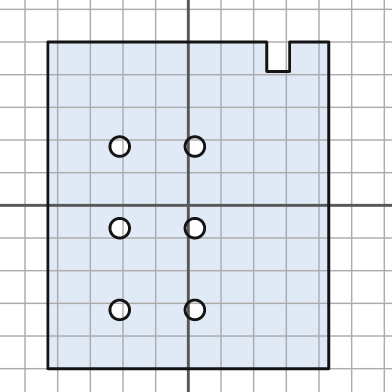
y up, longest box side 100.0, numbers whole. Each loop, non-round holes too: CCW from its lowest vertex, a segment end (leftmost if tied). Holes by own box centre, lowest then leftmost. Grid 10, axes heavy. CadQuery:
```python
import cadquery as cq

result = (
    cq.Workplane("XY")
    .moveTo(-43.0, -50.0)
    .lineTo(43.0, -50.0)
    .lineTo(43.0, 50.0)
    .lineTo(31.0, 50.0)
    .lineTo(31.0, 41.0)
    .lineTo(24.0, 41.0)
    .lineTo(24.0, 50.0)
    .lineTo(-43.0, 50.0)
    .close()
    .moveTo(-21.0, -32.0)
    .circle(3.0)
    .moveTo(2.0, -32.0)
    .circle(3.0)
    .moveTo(-21.0, -7.0)
    .circle(3.0)
    .moveTo(2.0, -7.0)
    .circle(3.0)
    .moveTo(-21.0, 18.0)
    .circle(3.0)
    .moveTo(2.0, 18.0)
    .circle(3.0)
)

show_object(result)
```